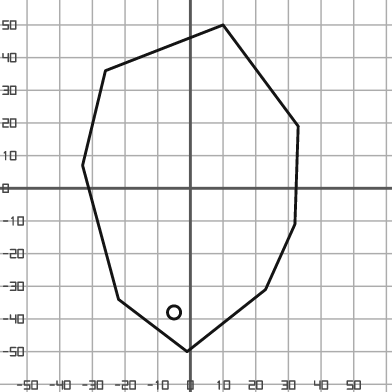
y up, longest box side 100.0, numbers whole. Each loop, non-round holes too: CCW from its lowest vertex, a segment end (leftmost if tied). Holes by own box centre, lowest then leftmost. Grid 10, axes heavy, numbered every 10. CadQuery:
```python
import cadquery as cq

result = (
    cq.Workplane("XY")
    .moveTo(-1.0, -50.0)
    .lineTo(23.0, -31.0)
    .lineTo(32.0, -11.0)
    .lineTo(33.0, 19.0)
    .lineTo(10.0, 50.0)
    .lineTo(-26.0, 36.0)
    .lineTo(-33.0, 7.0)
    .lineTo(-22.0, -34.0)
    .close()
    .moveTo(-5.0, -38.0)
    .circle(2.0)
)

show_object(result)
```